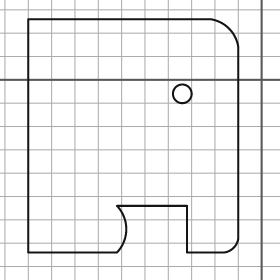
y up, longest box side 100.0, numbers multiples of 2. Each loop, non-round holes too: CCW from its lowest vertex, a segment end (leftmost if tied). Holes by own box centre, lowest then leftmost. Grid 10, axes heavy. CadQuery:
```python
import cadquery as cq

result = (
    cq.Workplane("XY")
    .moveTo(-100.0, -74.0)
    .lineTo(-62.0, -74.0)
    .threePointArc((-58.0, -64.0), (-62.0, -54.0))
    .lineTo(-32.0, -54.0)
    .lineTo(-32.0, -74.0)
    .lineTo(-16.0, -74.0)
    .threePointArc((-12.0, -72.0), (-10.0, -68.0))
    .lineTo(-10.0, 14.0)
    .threePointArc((-14.0, 22.0), (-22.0, 26.0))
    .lineTo(-100.0, 26.0)
    .close()
    .moveTo(-34.0, -6.0)
    .circle(4.0)
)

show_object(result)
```